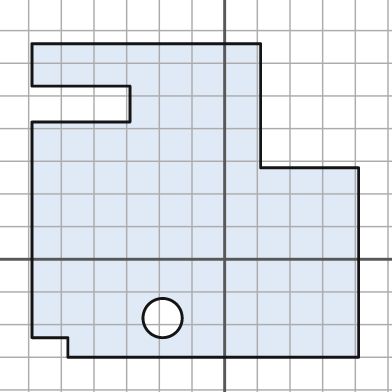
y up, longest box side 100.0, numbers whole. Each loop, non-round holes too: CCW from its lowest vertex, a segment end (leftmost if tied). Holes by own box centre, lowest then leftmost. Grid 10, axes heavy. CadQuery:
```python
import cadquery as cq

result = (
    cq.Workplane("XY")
    .moveTo(-48.0, -30.0)
    .lineTo(41.0, -30.0)
    .lineTo(41.0, 28.0)
    .lineTo(11.0, 28.0)
    .lineTo(11.0, 66.0)
    .lineTo(-59.0, 66.0)
    .lineTo(-59.0, 53.0)
    .lineTo(-29.0, 53.0)
    .lineTo(-29.0, 42.0)
    .lineTo(-59.0, 42.0)
    .lineTo(-59.0, -24.0)
    .lineTo(-48.0, -24.0)
    .close()
    .moveTo(-19.0, -18.0)
    .circle(6.0)
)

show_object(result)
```